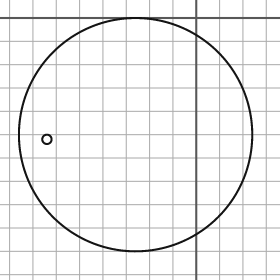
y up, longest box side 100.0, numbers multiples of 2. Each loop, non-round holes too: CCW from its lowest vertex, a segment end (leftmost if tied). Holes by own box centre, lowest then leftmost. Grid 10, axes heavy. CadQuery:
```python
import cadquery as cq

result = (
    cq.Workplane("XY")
    .moveTo(-26.0, -50.0)
    .circle(50.0)
    .moveTo(-64.0, -52.0)
    .circle(2.0)
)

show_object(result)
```